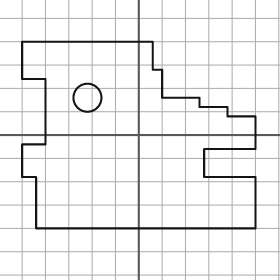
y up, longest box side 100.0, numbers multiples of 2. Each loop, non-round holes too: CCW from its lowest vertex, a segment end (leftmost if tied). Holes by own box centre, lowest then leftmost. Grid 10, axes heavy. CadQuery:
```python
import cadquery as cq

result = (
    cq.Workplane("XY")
    .moveTo(-44.0, -40.0)
    .lineTo(50.0, -40.0)
    .lineTo(50.0, -18.0)
    .lineTo(28.0, -18.0)
    .lineTo(28.0, -6.0)
    .lineTo(50.0, -6.0)
    .lineTo(50.0, 8.0)
    .lineTo(38.0, 8.0)
    .lineTo(38.0, 12.0)
    .lineTo(26.0, 12.0)
    .lineTo(26.0, 16.0)
    .lineTo(10.0, 16.0)
    .lineTo(10.0, 28.0)
    .lineTo(6.0, 28.0)
    .lineTo(6.0, 40.0)
    .lineTo(-50.0, 40.0)
    .lineTo(-50.0, 24.0)
    .lineTo(-40.0, 24.0)
    .lineTo(-40.0, -4.0)
    .lineTo(-50.0, -4.0)
    .lineTo(-50.0, -18.0)
    .lineTo(-44.0, -18.0)
    .close()
    .moveTo(-22.0, 16.0)
    .circle(6.0)
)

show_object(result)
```